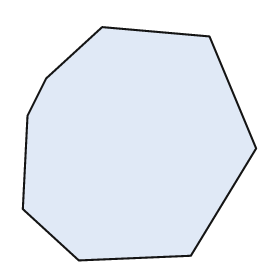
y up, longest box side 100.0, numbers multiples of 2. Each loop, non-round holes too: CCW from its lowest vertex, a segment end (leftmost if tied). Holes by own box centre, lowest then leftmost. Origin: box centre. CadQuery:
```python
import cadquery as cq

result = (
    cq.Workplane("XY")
    .moveTo(-26.0, -50.0)
    .lineTo(22.0, -48.0)
    .lineTo(50.0, -2.0)
    .lineTo(30.0, 46.0)
    .lineTo(-16.0, 50.0)
    .lineTo(-40.0, 28.0)
    .lineTo(-48.0, 12.0)
    .lineTo(-50.0, -28.0)
    .close()
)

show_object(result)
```